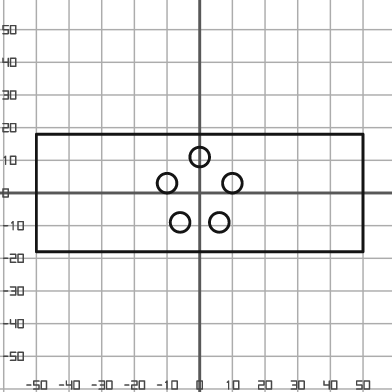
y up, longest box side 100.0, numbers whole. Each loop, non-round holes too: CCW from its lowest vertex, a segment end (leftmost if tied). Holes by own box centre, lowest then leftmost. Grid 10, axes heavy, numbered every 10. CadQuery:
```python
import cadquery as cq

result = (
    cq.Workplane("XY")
    .moveTo(-50.0, -18.0)
    .lineTo(50.0, -18.0)
    .lineTo(50.0, 18.0)
    .lineTo(-50.0, 18.0)
    .close()
    .moveTo(-6.0, -9.0)
    .circle(3.0)
    .moveTo(6.0, -9.0)
    .circle(3.0)
    .moveTo(-10.0, 3.0)
    .circle(3.0)
    .moveTo(10.0, 3.0)
    .circle(3.0)
    .moveTo(0.0, 11.0)
    .circle(3.0)
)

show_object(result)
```